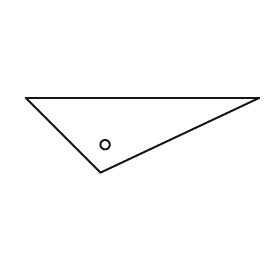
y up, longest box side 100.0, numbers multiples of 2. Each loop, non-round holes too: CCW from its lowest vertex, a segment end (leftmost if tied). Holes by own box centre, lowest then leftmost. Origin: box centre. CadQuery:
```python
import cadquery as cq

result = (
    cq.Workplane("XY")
    .moveTo(-18.0, -16.0)
    .lineTo(50.0, 16.0)
    .lineTo(-50.0, 16.0)
    .close()
    .moveTo(-16.0, -4.0)
    .circle(2.0)
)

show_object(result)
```